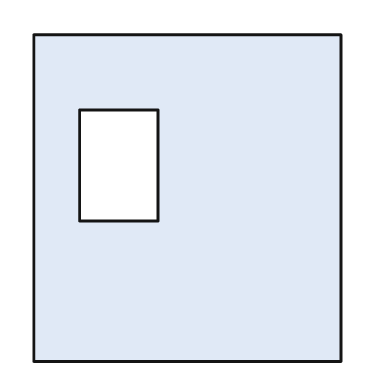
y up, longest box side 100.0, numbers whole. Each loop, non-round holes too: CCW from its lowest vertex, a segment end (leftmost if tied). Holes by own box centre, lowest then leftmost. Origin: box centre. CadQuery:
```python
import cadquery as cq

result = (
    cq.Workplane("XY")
    .moveTo(-47.0, -50.0)
    .lineTo(47.0, -50.0)
    .lineTo(47.0, 50.0)
    .lineTo(-47.0, 50.0)
    .close()
    .moveTo(-33.0, -7.0)
    .lineTo(-9.0, -7.0)
    .lineTo(-9.0, 27.0)
    .lineTo(-33.0, 27.0)
    .close()
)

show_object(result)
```